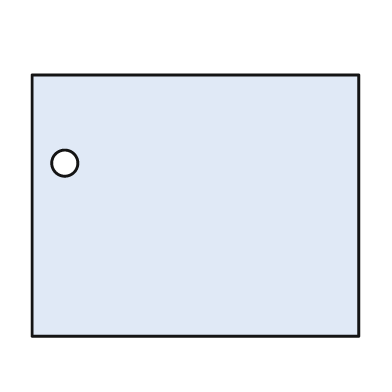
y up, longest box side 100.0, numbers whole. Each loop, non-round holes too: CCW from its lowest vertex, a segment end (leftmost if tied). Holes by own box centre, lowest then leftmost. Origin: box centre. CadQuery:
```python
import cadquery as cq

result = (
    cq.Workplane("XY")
    .moveTo(-50.0, -40.0)
    .lineTo(50.0, -40.0)
    .lineTo(50.0, 40.0)
    .lineTo(-50.0, 40.0)
    .close()
    .moveTo(-40.0, 13.0)
    .circle(4.0)
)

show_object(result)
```